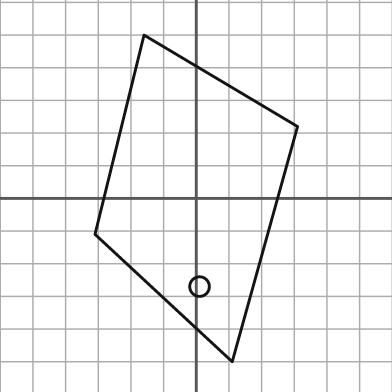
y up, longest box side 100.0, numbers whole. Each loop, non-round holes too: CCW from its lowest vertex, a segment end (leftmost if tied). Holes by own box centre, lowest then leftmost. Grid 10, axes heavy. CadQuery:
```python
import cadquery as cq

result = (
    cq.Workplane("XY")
    .moveTo(11.0, -50.0)
    .lineTo(31.0, 22.0)
    .lineTo(-16.0, 50.0)
    .lineTo(-31.0, -11.0)
    .close()
    .moveTo(1.0, -27.0)
    .circle(3.0)
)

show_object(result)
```